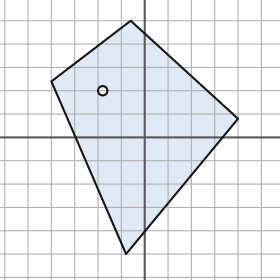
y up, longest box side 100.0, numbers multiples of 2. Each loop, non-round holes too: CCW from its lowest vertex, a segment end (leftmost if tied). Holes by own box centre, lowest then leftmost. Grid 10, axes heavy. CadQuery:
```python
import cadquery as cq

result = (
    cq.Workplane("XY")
    .moveTo(-8.0, -50.0)
    .lineTo(40.0, 8.0)
    .lineTo(-6.0, 50.0)
    .lineTo(-40.0, 24.0)
    .close()
    .moveTo(-18.0, 20.0)
    .circle(2.0)
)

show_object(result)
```